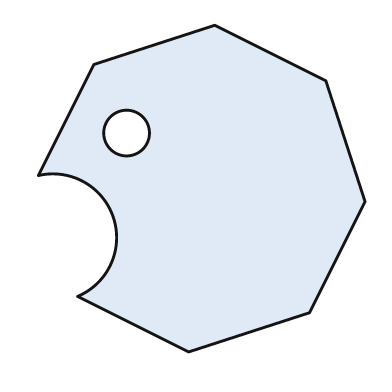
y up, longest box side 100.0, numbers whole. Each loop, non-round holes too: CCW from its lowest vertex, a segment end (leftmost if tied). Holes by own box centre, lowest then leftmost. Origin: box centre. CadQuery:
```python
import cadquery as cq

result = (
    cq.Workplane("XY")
    .moveTo(-4.0, -50.0)
    .lineTo(33.0, -38.0)
    .lineTo(50.0, -4.0)
    .lineTo(38.0, 33.0)
    .lineTo(4.0, 50.0)
    .lineTo(-33.0, 38.0)
    .lineTo(-50.0, 4.0)
    .threePointArc((-27.0, -9.0), (-38.0, -33.0))
    .close()
    .moveTo(-23.0, 17.0)
    .circle(7.0)
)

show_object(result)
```